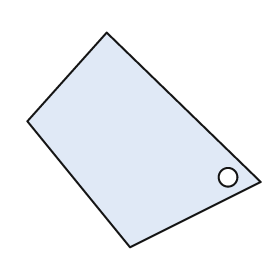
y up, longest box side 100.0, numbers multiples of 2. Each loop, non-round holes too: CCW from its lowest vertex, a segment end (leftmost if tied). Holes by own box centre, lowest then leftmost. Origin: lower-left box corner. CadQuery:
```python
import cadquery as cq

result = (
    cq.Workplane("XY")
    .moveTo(44.0, 0.0)
    .lineTo(100.0, 28.0)
    .lineTo(34.0, 92.0)
    .lineTo(0.0, 54.0)
    .close()
    .moveTo(86.0, 30.0)
    .circle(4.0)
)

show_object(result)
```